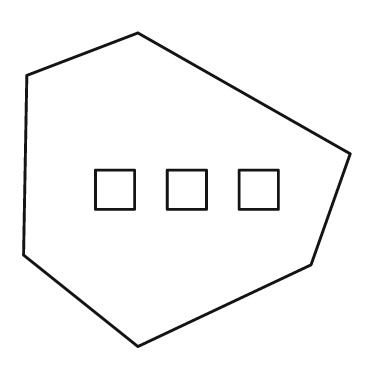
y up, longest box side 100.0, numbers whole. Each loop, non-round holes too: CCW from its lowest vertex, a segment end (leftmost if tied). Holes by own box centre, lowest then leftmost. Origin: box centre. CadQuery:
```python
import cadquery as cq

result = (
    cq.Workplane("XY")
    .moveTo(-15.0, -48.0)
    .lineTo(38.0, -23.0)
    .lineTo(50.0, 11.0)
    .lineTo(-15.0, 48.0)
    .lineTo(-49.0, 35.0)
    .lineTo(-50.0, -20.0)
    .close()
    .moveTo(-28.0, -6.0)
    .lineTo(-16.0, -6.0)
    .lineTo(-16.0, 6.0)
    .lineTo(-28.0, 6.0)
    .close()
    .moveTo(-6.0, -6.0)
    .lineTo(6.0, -6.0)
    .lineTo(6.0, 6.0)
    .lineTo(-6.0, 6.0)
    .close()
    .moveTo(16.0, -6.0)
    .lineTo(28.0, -6.0)
    .lineTo(28.0, 6.0)
    .lineTo(16.0, 6.0)
    .close()
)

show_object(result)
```